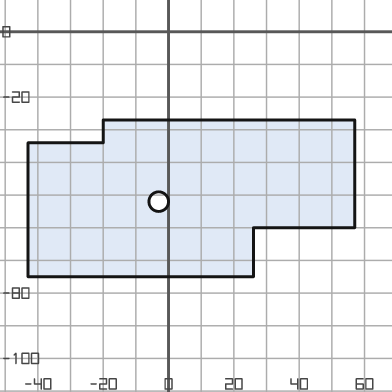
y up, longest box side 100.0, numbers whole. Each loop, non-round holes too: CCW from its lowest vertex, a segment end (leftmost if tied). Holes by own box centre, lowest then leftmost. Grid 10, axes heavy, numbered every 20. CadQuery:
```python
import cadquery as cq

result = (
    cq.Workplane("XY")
    .moveTo(-43.0, -75.0)
    .lineTo(26.0, -75.0)
    .lineTo(26.0, -60.0)
    .lineTo(57.0, -60.0)
    .lineTo(57.0, -27.0)
    .lineTo(-20.0, -27.0)
    .lineTo(-20.0, -34.0)
    .lineTo(-43.0, -34.0)
    .close()
    .moveTo(-3.0, -52.0)
    .circle(3.0)
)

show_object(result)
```